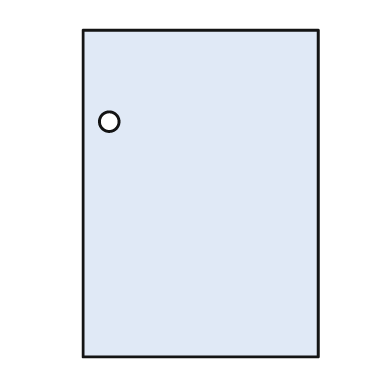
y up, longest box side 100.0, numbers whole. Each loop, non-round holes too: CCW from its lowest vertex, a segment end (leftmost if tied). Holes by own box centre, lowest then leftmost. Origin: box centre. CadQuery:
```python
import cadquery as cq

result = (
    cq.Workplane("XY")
    .moveTo(-36.0, -50.0)
    .lineTo(36.0, -50.0)
    .lineTo(36.0, 50.0)
    .lineTo(-36.0, 50.0)
    .close()
    .moveTo(-28.0, 22.0)
    .circle(3.0)
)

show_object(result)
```